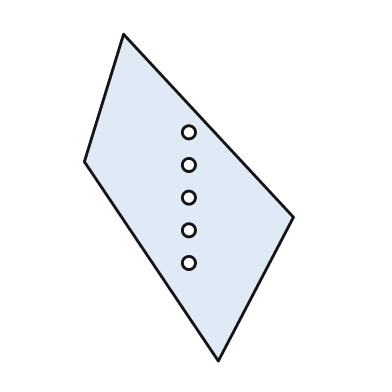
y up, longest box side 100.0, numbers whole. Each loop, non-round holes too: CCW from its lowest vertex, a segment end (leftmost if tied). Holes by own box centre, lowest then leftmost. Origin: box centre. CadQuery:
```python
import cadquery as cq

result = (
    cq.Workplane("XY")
    .moveTo(9.0, -50.0)
    .lineTo(32.0, -6.0)
    .lineTo(-20.0, 50.0)
    .lineTo(-32.0, 11.0)
    .close()
    .moveTo(0.0, -20.0)
    .circle(2.0)
    .moveTo(0.0, -10.0)
    .circle(2.0)
    .moveTo(0.0, 0.0)
    .circle(2.0)
    .moveTo(0.0, 10.0)
    .circle(2.0)
    .moveTo(0.0, 20.0)
    .circle(2.0)
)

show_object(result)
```